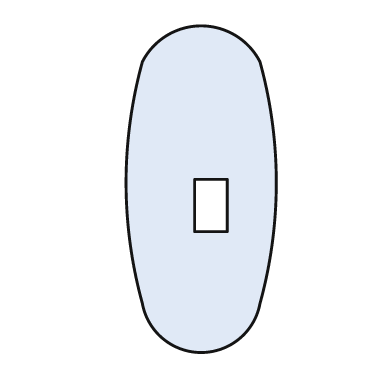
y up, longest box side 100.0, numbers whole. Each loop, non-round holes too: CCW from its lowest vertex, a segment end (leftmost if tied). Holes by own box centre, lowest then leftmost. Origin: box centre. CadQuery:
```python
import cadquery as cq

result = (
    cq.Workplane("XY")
    .moveTo(-18.0, -35.0)
    .threePointArc((0.0, -50.0), (18.0, -35.0))
    .threePointArc((23.0, 2.0), (18.0, 39.0))
    .threePointArc((0.0, 50.0), (-18.0, 39.0))
    .threePointArc((-23.0, 2.0), (-18.0, -35.0))
    .close()
    .moveTo(-2.0, -13.0)
    .lineTo(8.0, -13.0)
    .lineTo(8.0, 3.0)
    .lineTo(-2.0, 3.0)
    .close()
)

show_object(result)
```